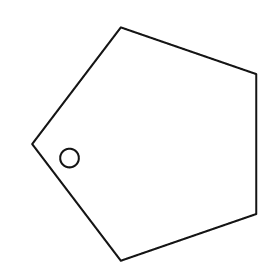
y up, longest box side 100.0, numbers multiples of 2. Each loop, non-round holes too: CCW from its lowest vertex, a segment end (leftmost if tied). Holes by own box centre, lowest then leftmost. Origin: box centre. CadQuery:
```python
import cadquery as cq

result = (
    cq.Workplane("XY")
    .moveTo(-10.0, -50.0)
    .lineTo(48.0, -30.0)
    .lineTo(48.0, 30.0)
    .lineTo(-10.0, 50.0)
    .lineTo(-48.0, 0.0)
    .close()
    .moveTo(-32.0, -6.0)
    .circle(4.0)
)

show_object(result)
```